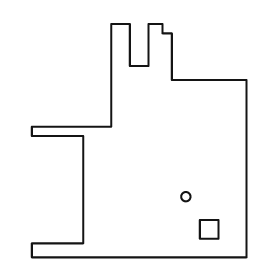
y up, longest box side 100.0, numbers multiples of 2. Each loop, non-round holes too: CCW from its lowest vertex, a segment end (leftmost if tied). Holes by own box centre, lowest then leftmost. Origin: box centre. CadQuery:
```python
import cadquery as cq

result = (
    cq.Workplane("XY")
    .moveTo(-46.0, -50.0)
    .lineTo(46.0, -50.0)
    .lineTo(46.0, 26.0)
    .lineTo(14.0, 26.0)
    .lineTo(14.0, 46.0)
    .lineTo(10.0, 46.0)
    .lineTo(10.0, 50.0)
    .lineTo(4.0, 50.0)
    .lineTo(4.0, 32.0)
    .lineTo(-4.0, 32.0)
    .lineTo(-4.0, 50.0)
    .lineTo(-12.0, 50.0)
    .lineTo(-12.0, 6.0)
    .lineTo(-46.0, 6.0)
    .lineTo(-46.0, 2.0)
    .lineTo(-24.0, 2.0)
    .lineTo(-24.0, -44.0)
    .lineTo(-46.0, -44.0)
    .close()
    .moveTo(26.0, -42.0)
    .lineTo(34.0, -42.0)
    .lineTo(34.0, -34.0)
    .lineTo(26.0, -34.0)
    .close()
    .moveTo(20.0, -24.0)
    .circle(2.0)
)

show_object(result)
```